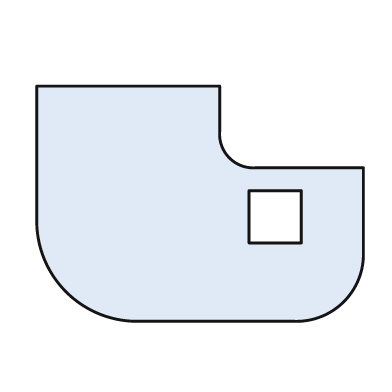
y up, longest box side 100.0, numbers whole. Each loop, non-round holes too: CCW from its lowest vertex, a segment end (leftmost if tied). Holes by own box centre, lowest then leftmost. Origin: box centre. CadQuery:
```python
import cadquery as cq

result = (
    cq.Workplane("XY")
    .moveTo(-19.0, -36.0)
    .lineTo(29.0, -36.0)
    .threePointArc((44.0, -30.0), (50.0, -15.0))
    .lineTo(50.0, 11.0)
    .lineTo(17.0, 11.0)
    .threePointArc((9.0, 14.0), (6.0, 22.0))
    .lineTo(6.0, 36.0)
    .lineTo(-50.0, 36.0)
    .lineTo(-50.0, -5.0)
    .threePointArc((-41.0, -27.0), (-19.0, -36.0))
    .close()
    .moveTo(15.0, -12.0)
    .lineTo(31.0, -12.0)
    .lineTo(31.0, 4.0)
    .lineTo(15.0, 4.0)
    .close()
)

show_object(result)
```